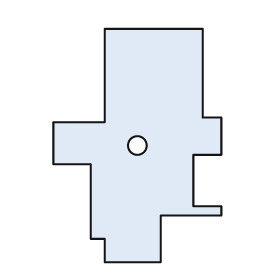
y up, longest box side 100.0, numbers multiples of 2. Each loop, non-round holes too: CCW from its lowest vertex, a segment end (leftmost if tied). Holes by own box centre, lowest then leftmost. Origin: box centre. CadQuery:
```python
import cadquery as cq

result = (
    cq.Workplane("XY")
    .moveTo(-14.0, -50.0)
    .lineTo(10.0, -50.0)
    .lineTo(10.0, -30.0)
    .lineTo(36.0, -30.0)
    .lineTo(36.0, -26.0)
    .lineTo(24.0, -26.0)
    .lineTo(24.0, -4.0)
    .lineTo(36.0, -4.0)
    .lineTo(36.0, 12.0)
    .lineTo(28.0, 12.0)
    .lineTo(28.0, 50.0)
    .lineTo(-14.0, 50.0)
    .lineTo(-14.0, 10.0)
    .lineTo(-36.0, 10.0)
    .lineTo(-36.0, -8.0)
    .lineTo(-20.0, -8.0)
    .lineTo(-20.0, -40.0)
    .lineTo(-14.0, -40.0)
    .close()
    .moveTo(0.0, 0.0)
    .circle(4.0)
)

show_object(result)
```